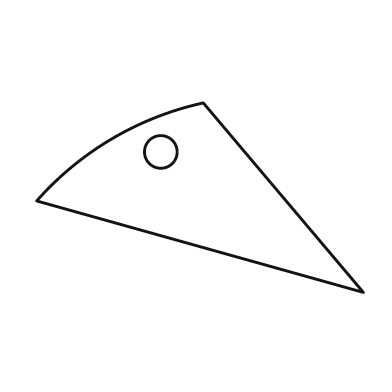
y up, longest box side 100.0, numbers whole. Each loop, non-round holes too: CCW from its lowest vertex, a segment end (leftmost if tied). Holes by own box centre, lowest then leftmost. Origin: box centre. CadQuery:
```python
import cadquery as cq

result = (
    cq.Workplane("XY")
    .moveTo(50.0, -29.0)
    .lineTo(1.0, 29.0)
    .threePointArc((-27.0, 18.0), (-50.0, -1.0))
    .close()
    .moveTo(-12.0, 14.0)
    .circle(5.0)
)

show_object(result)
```